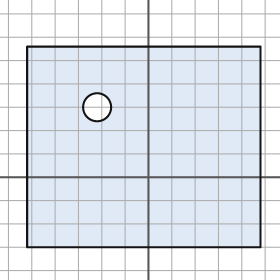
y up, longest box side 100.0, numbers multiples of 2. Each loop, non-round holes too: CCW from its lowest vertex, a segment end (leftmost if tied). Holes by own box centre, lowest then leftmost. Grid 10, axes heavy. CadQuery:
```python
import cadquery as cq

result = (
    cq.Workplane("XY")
    .moveTo(-52.0, -30.0)
    .lineTo(48.0, -30.0)
    .lineTo(48.0, 56.0)
    .lineTo(-52.0, 56.0)
    .close()
    .moveTo(-22.0, 30.0)
    .circle(6.0)
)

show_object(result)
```